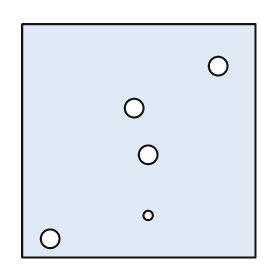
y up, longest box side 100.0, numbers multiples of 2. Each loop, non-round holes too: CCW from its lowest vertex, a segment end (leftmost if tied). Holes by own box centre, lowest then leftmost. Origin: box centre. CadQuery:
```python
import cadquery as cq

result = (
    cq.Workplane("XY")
    .moveTo(-50.0, -50.0)
    .lineTo(50.0, -50.0)
    .lineTo(50.0, 50.0)
    .lineTo(-50.0, 50.0)
    .close()
    .moveTo(-38.0, -42.0)
    .circle(4.0)
    .moveTo(4.0, -32.0)
    .circle(2.0)
    .moveTo(4.0, -6.0)
    .circle(4.0)
    .moveTo(-2.0, 14.0)
    .circle(4.0)
    .moveTo(34.0, 32.0)
    .circle(4.0)
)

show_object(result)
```